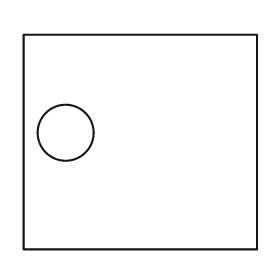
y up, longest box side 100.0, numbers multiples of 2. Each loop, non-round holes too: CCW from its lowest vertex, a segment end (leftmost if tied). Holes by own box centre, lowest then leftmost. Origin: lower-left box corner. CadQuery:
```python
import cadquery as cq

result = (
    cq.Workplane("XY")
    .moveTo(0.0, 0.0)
    .lineTo(100.0, 0.0)
    .lineTo(100.0, 92.0)
    .lineTo(0.0, 92.0)
    .close()
    .moveTo(18.0, 50.0)
    .circle(12.0)
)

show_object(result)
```